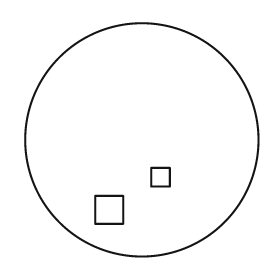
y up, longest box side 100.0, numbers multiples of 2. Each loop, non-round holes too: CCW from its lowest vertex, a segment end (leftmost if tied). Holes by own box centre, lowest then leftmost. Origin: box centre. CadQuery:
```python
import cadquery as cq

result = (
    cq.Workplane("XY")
    .moveTo(0.0, 0.0)
    .circle(50.0)
    .moveTo(-20.0, -36.0)
    .lineTo(-8.0, -36.0)
    .lineTo(-8.0, -24.0)
    .lineTo(-20.0, -24.0)
    .close()
    .moveTo(4.0, -20.0)
    .lineTo(12.0, -20.0)
    .lineTo(12.0, -12.0)
    .lineTo(4.0, -12.0)
    .close()
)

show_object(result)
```